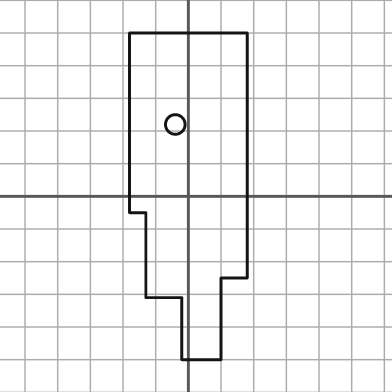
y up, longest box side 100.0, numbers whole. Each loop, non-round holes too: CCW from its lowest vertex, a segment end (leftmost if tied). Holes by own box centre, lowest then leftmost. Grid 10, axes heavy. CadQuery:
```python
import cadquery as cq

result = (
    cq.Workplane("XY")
    .moveTo(-2.0, -50.0)
    .lineTo(10.0, -50.0)
    .lineTo(10.0, -25.0)
    .lineTo(18.0, -25.0)
    .lineTo(18.0, 50.0)
    .lineTo(-18.0, 50.0)
    .lineTo(-18.0, -5.0)
    .lineTo(-13.0, -5.0)
    .lineTo(-13.0, -31.0)
    .lineTo(-2.0, -31.0)
    .close()
    .moveTo(-4.0, 22.0)
    .circle(3.0)
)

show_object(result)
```